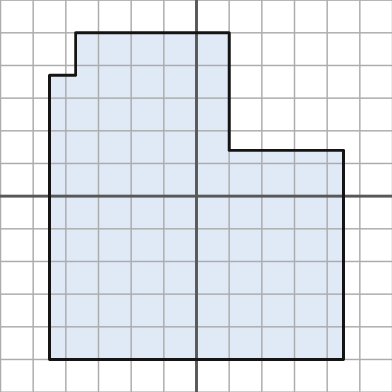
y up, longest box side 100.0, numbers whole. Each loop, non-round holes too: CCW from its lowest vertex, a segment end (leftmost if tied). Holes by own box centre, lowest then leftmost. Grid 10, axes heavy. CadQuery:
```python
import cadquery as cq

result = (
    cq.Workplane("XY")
    .moveTo(-45.0, -50.0)
    .lineTo(45.0, -50.0)
    .lineTo(45.0, 14.0)
    .lineTo(10.0, 14.0)
    .lineTo(10.0, 50.0)
    .lineTo(-37.0, 50.0)
    .lineTo(-37.0, 37.0)
    .lineTo(-45.0, 37.0)
    .close()
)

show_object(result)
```